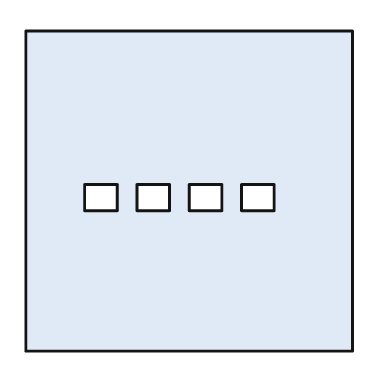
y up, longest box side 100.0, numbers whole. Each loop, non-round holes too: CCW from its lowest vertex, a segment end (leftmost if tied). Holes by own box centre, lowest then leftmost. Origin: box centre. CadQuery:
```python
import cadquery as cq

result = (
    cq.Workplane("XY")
    .moveTo(-50.0, -49.0)
    .lineTo(50.0, -49.0)
    .lineTo(50.0, 49.0)
    .lineTo(-50.0, 49.0)
    .close()
    .moveTo(-32.0, -6.0)
    .lineTo(-22.0, -6.0)
    .lineTo(-22.0, 2.0)
    .lineTo(-32.0, 2.0)
    .close()
    .moveTo(-16.0, -6.0)
    .lineTo(-6.0, -6.0)
    .lineTo(-6.0, 2.0)
    .lineTo(-16.0, 2.0)
    .close()
    .moveTo(0.0, -6.0)
    .lineTo(10.0, -6.0)
    .lineTo(10.0, 2.0)
    .lineTo(0.0, 2.0)
    .close()
    .moveTo(16.0, -6.0)
    .lineTo(26.0, -6.0)
    .lineTo(26.0, 2.0)
    .lineTo(16.0, 2.0)
    .close()
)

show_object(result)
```